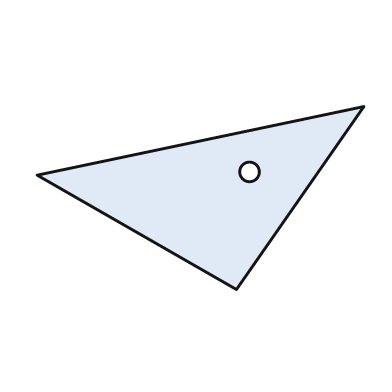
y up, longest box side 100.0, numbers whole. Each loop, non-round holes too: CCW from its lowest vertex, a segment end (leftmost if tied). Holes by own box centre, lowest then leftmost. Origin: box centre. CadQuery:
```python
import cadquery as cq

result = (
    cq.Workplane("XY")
    .moveTo(11.0, -28.0)
    .lineTo(50.0, 28.0)
    .lineTo(-50.0, 7.0)
    .close()
    .moveTo(15.0, 8.0)
    .circle(3.0)
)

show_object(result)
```